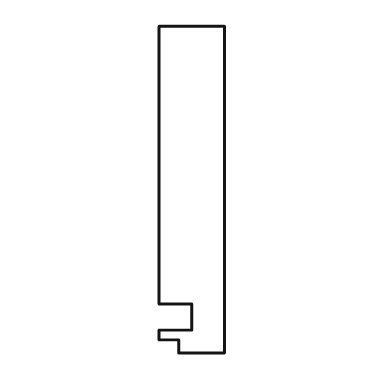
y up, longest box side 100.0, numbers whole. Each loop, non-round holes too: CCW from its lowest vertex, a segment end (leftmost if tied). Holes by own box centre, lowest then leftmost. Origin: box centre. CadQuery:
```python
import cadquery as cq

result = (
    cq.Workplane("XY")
    .moveTo(-4.0, -50.0)
    .lineTo(10.0, -50.0)
    .lineTo(10.0, 50.0)
    .lineTo(-10.0, 50.0)
    .lineTo(-10.0, -35.0)
    .lineTo(0.0, -35.0)
    .lineTo(0.0, -43.0)
    .lineTo(-10.0, -43.0)
    .lineTo(-10.0, -46.0)
    .lineTo(-4.0, -46.0)
    .close()
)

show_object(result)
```